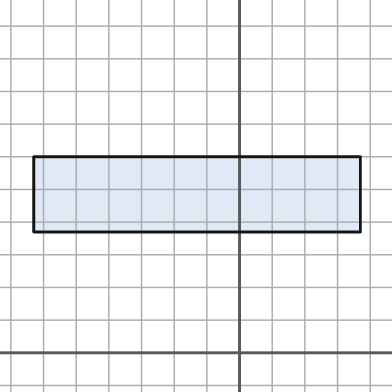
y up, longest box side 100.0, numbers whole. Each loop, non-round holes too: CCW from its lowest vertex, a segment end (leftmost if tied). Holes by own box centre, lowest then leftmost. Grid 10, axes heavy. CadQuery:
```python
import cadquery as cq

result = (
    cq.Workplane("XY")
    .moveTo(-63.0, 37.0)
    .lineTo(37.0, 37.0)
    .lineTo(37.0, 60.0)
    .lineTo(-63.0, 60.0)
    .close()
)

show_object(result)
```